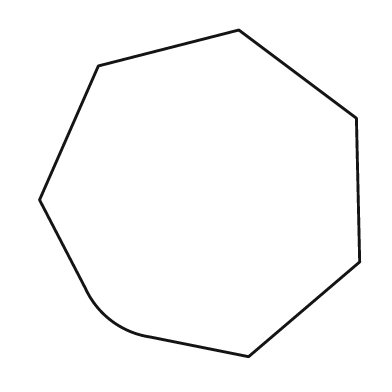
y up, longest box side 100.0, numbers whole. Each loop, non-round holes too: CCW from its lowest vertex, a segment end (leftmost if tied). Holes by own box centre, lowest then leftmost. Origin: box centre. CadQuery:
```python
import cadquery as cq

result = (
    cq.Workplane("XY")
    .moveTo(15.0, -50.0)
    .lineTo(49.0, -21.0)
    .lineTo(48.0, 23.0)
    .lineTo(12.0, 50.0)
    .lineTo(-31.0, 39.0)
    .lineTo(-49.0, -2.0)
    .lineTo(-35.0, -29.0)
    .threePointArc((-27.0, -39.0), (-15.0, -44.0))
    .close()
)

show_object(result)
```